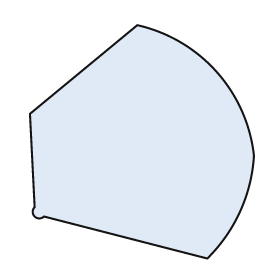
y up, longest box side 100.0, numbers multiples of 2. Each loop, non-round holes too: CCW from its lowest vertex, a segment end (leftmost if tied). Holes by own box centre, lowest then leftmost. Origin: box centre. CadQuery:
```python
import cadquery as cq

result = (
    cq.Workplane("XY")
    .moveTo(28.0, -50.0)
    .threePointArc((42.0, -30.0), (48.0, -6.0))
    .threePointArc((32.0, 30.0), (-2.0, 50.0))
    .lineTo(-48.0, 12.0)
    .lineTo(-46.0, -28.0)
    .threePointArc((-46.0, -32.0), (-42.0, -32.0))
    .close()
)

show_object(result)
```